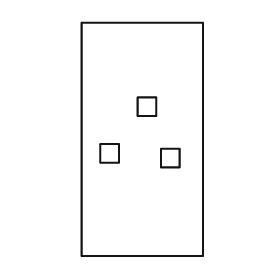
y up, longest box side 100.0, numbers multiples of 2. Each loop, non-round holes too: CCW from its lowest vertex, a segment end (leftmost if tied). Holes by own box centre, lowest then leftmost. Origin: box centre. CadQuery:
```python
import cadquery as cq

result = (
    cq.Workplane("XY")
    .moveTo(-26.0, -50.0)
    .lineTo(26.0, -50.0)
    .lineTo(26.0, 50.0)
    .lineTo(-26.0, 50.0)
    .close()
    .moveTo(8.0, -12.0)
    .lineTo(16.0, -12.0)
    .lineTo(16.0, -4.0)
    .lineTo(8.0, -4.0)
    .close()
    .moveTo(-18.0, -10.0)
    .lineTo(-10.0, -10.0)
    .lineTo(-10.0, -2.0)
    .lineTo(-18.0, -2.0)
    .close()
    .moveTo(-2.0, 10.0)
    .lineTo(6.0, 10.0)
    .lineTo(6.0, 18.0)
    .lineTo(-2.0, 18.0)
    .close()
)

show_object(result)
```